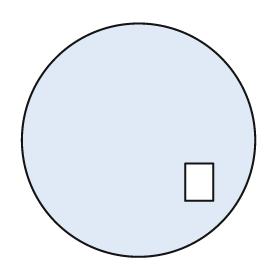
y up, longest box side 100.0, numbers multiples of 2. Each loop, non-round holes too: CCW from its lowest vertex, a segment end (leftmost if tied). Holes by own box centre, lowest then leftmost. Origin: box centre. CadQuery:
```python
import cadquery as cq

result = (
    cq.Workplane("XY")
    .moveTo(0.0, 0.0)
    .circle(50.0)
    .moveTo(20.0, -26.0)
    .lineTo(32.0, -26.0)
    .lineTo(32.0, -10.0)
    .lineTo(20.0, -10.0)
    .close()
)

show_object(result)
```